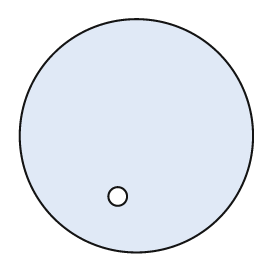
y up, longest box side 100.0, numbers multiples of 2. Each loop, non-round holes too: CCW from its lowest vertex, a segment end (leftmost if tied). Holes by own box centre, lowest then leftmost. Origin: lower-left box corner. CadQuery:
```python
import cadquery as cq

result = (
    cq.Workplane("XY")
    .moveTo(50.0, 50.0)
    .circle(50.0)
    .moveTo(42.0, 24.0)
    .circle(4.0)
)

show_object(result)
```